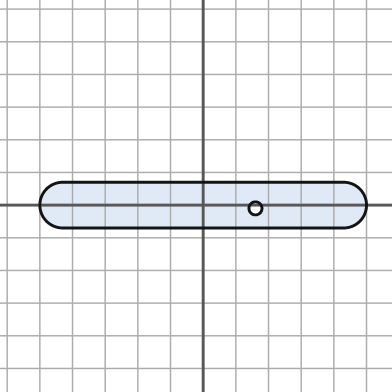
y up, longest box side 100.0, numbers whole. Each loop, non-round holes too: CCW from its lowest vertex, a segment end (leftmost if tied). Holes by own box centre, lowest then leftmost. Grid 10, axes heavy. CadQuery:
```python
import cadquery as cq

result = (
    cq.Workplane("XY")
    .moveTo(-43.0, -7.0)
    .lineTo(43.0, -7.0)
    .threePointArc((50.0, 0.0), (43.0, 7.0))
    .lineTo(-43.0, 7.0)
    .threePointArc((-50.0, 0.0), (-43.0, -7.0))
    .close()
    .moveTo(16.0, -1.0)
    .circle(2.0)
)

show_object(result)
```